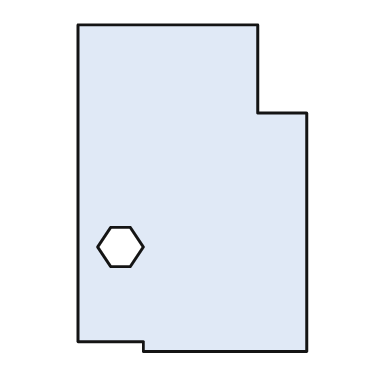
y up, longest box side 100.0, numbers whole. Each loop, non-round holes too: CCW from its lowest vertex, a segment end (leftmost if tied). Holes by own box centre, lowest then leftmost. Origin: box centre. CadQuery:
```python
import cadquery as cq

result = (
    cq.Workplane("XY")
    .moveTo(-15.0, -50.0)
    .lineTo(35.0, -50.0)
    .lineTo(35.0, 23.0)
    .lineTo(20.0, 23.0)
    .lineTo(20.0, 50.0)
    .lineTo(-35.0, 50.0)
    .lineTo(-35.0, -47.0)
    .lineTo(-15.0, -47.0)
    .close()
    .moveTo(-25.0, -24.0)
    .lineTo(-19.0, -24.0)
    .lineTo(-15.0, -18.0)
    .lineTo(-19.0, -12.0)
    .lineTo(-25.0, -12.0)
    .lineTo(-29.0, -18.0)
    .close()
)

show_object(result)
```